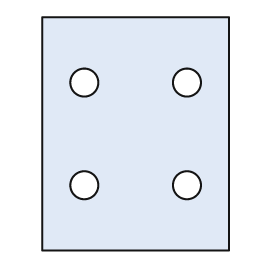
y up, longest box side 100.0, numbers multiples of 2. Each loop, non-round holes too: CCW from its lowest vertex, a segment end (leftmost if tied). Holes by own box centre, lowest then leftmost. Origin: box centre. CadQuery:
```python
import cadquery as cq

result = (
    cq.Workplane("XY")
    .moveTo(-40.0, -50.0)
    .lineTo(40.0, -50.0)
    .lineTo(40.0, 50.0)
    .lineTo(-40.0, 50.0)
    .close()
    .moveTo(-22.0, -22.0)
    .circle(6.0)
    .moveTo(22.0, -22.0)
    .circle(6.0)
    .moveTo(-22.0, 22.0)
    .circle(6.0)
    .moveTo(22.0, 22.0)
    .circle(6.0)
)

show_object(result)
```